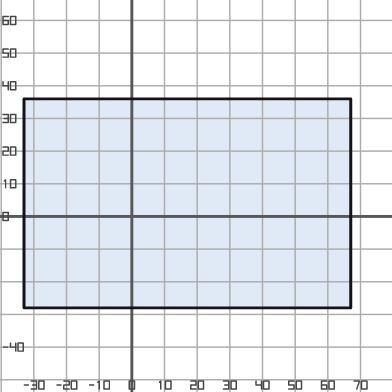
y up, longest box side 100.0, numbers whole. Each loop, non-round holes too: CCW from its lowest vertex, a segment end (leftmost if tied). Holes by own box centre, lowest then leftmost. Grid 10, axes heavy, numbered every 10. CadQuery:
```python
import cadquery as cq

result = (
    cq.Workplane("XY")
    .moveTo(-33.0, -28.0)
    .lineTo(67.0, -28.0)
    .lineTo(67.0, 36.0)
    .lineTo(-33.0, 36.0)
    .close()
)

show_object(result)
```